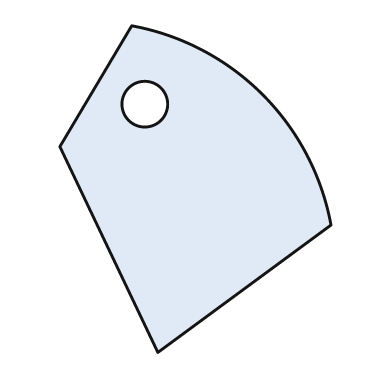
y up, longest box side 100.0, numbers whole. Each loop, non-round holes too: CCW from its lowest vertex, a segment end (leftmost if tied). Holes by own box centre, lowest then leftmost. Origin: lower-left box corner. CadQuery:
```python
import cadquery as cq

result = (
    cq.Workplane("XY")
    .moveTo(30.0, 0.0)
    .lineTo(83.0, 39.0)
    .threePointArc((62.0, 79.0), (22.0, 100.0))
    .lineTo(0.0, 63.0)
    .close()
    .moveTo(26.0, 76.0)
    .circle(7.0)
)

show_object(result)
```